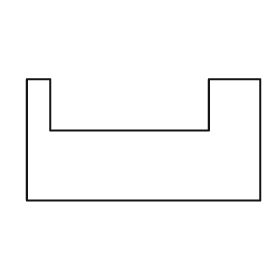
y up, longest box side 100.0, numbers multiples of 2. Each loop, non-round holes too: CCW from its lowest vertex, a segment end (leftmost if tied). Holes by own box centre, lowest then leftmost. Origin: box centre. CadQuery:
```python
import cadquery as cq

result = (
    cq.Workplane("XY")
    .moveTo(-50.0, -26.0)
    .lineTo(50.0, -26.0)
    .lineTo(50.0, 26.0)
    .lineTo(28.0, 26.0)
    .lineTo(28.0, 4.0)
    .lineTo(-40.0, 4.0)
    .lineTo(-40.0, 26.0)
    .lineTo(-50.0, 26.0)
    .close()
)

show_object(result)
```